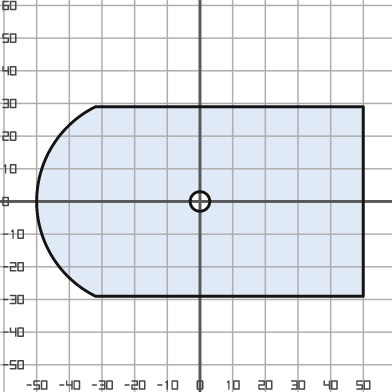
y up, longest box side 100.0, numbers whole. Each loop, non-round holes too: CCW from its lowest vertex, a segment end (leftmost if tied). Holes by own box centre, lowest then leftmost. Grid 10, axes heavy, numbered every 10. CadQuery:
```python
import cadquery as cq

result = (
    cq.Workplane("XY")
    .moveTo(-32.0, -29.0)
    .lineTo(50.0, -29.0)
    .lineTo(50.0, 29.0)
    .lineTo(-32.0, 29.0)
    .threePointArc((-50.0, 0.0), (-32.0, -29.0))
    .close()
    .moveTo(0.0, 0.0)
    .circle(3.0)
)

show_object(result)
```